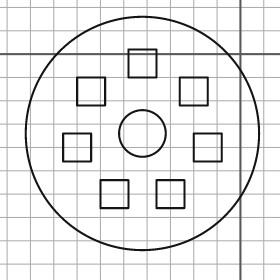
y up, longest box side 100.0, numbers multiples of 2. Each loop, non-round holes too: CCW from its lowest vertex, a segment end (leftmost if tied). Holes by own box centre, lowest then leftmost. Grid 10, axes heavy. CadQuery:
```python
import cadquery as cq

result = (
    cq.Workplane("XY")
    .moveTo(-42.0, -34.0)
    .circle(50.0)
    .moveTo(-60.0, -66.0)
    .lineTo(-48.0, -66.0)
    .lineTo(-48.0, -54.0)
    .lineTo(-60.0, -54.0)
    .close()
    .moveTo(-36.0, -66.0)
    .lineTo(-24.0, -66.0)
    .lineTo(-24.0, -54.0)
    .lineTo(-36.0, -54.0)
    .close()
    .moveTo(-76.0, -46.0)
    .lineTo(-64.0, -46.0)
    .lineTo(-64.0, -34.0)
    .lineTo(-76.0, -34.0)
    .close()
    .moveTo(-20.0, -46.0)
    .lineTo(-8.0, -46.0)
    .lineTo(-8.0, -34.0)
    .lineTo(-20.0, -34.0)
    .close()
    .moveTo(-42.0, -34.0)
    .circle(10.0)
    .moveTo(-70.0, -22.0)
    .lineTo(-58.0, -22.0)
    .lineTo(-58.0, -10.0)
    .lineTo(-70.0, -10.0)
    .close()
    .moveTo(-26.0, -22.0)
    .lineTo(-14.0, -22.0)
    .lineTo(-14.0, -10.0)
    .lineTo(-26.0, -10.0)
    .close()
    .moveTo(-48.0, -10.0)
    .lineTo(-36.0, -10.0)
    .lineTo(-36.0, 2.0)
    .lineTo(-48.0, 2.0)
    .close()
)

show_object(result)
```